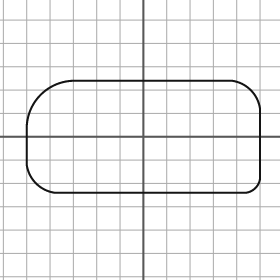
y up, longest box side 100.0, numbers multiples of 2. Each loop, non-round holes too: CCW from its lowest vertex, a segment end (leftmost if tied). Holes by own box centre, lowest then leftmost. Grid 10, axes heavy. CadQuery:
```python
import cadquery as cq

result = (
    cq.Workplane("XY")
    .moveTo(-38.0, -24.0)
    .lineTo(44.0, -24.0)
    .threePointArc((48.0, -22.0), (50.0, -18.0))
    .lineTo(50.0, 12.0)
    .threePointArc((46.0, 20.0), (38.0, 24.0))
    .lineTo(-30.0, 24.0)
    .threePointArc((-44.0, 18.0), (-50.0, 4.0))
    .lineTo(-50.0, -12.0)
    .threePointArc((-46.0, -20.0), (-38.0, -24.0))
    .close()
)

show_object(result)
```